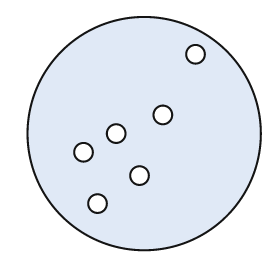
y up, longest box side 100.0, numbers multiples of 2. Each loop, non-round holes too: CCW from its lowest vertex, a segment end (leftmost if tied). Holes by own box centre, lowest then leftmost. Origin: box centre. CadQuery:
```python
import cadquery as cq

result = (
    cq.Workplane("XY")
    .moveTo(0.0, 0.0)
    .circle(50.0)
    .moveTo(-20.0, -30.0)
    .circle(4.0)
    .moveTo(-2.0, -18.0)
    .circle(4.0)
    .moveTo(-26.0, -8.0)
    .circle(4.0)
    .moveTo(-12.0, 0.0)
    .circle(4.0)
    .moveTo(8.0, 8.0)
    .circle(4.0)
    .moveTo(22.0, 34.0)
    .circle(4.0)
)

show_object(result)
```